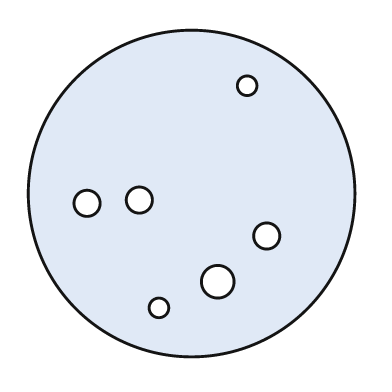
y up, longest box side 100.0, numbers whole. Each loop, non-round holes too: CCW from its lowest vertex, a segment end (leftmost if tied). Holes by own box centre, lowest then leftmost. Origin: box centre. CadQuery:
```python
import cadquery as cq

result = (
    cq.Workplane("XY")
    .moveTo(0.0, 0.0)
    .circle(50.0)
    .moveTo(-10.0, -35.0)
    .circle(3.0)
    .moveTo(8.0, -27.0)
    .circle(5.0)
    .moveTo(23.0, -13.0)
    .circle(4.0)
    .moveTo(-32.0, -3.0)
    .circle(4.0)
    .moveTo(-16.0, -2.0)
    .circle(4.0)
    .moveTo(17.0, 33.0)
    .circle(3.0)
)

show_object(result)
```